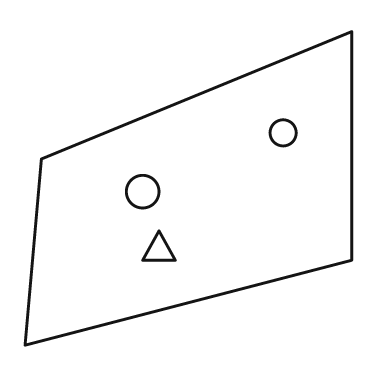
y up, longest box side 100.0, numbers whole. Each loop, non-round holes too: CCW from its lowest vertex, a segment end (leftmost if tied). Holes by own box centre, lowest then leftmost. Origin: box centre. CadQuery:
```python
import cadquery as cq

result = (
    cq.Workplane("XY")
    .moveTo(-50.0, -48.0)
    .lineTo(50.0, -22.0)
    .lineTo(50.0, 48.0)
    .lineTo(-45.0, 9.0)
    .close()
    .moveTo(-14.0, -22.0)
    .lineTo(-4.0, -22.0)
    .lineTo(-9.0, -13.0)
    .close()
    .moveTo(-14.0, -1.0)
    .circle(5.0)
    .moveTo(29.0, 17.0)
    .circle(4.0)
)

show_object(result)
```